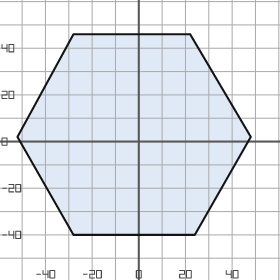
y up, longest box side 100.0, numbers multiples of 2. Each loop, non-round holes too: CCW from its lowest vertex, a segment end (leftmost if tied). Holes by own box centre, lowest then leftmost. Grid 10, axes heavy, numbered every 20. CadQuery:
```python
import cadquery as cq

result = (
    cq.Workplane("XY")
    .moveTo(-28.0, -40.0)
    .lineTo(24.0, -40.0)
    .lineTo(48.0, 2.0)
    .lineTo(22.0, 46.0)
    .lineTo(-28.0, 46.0)
    .lineTo(-52.0, 2.0)
    .close()
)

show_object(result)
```